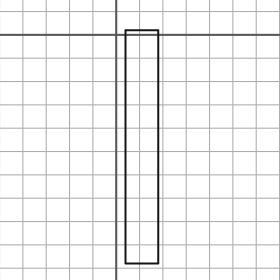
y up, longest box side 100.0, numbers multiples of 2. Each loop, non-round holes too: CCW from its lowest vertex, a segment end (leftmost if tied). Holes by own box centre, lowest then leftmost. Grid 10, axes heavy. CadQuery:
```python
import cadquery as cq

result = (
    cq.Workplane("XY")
    .moveTo(4.0, -98.0)
    .lineTo(18.0, -98.0)
    .lineTo(18.0, 2.0)
    .lineTo(4.0, 2.0)
    .close()
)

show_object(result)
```